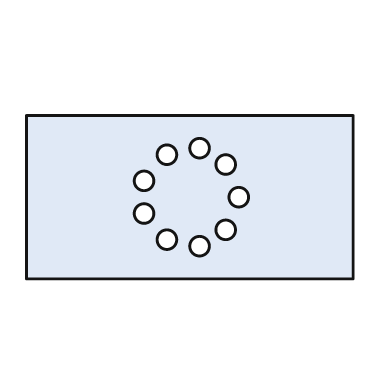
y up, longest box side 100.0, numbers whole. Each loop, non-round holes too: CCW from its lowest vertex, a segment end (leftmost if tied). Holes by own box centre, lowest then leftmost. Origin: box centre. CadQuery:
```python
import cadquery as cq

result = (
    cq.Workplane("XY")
    .moveTo(-50.0, -25.0)
    .lineTo(50.0, -25.0)
    .lineTo(50.0, 25.0)
    .lineTo(-50.0, 25.0)
    .close()
    .moveTo(3.0, -15.0)
    .circle(3.0)
    .moveTo(-7.0, -13.0)
    .circle(3.0)
    .moveTo(11.0, -10.0)
    .circle(3.0)
    .moveTo(-14.0, -5.0)
    .circle(3.0)
    .moveTo(15.0, 0.0)
    .circle(3.0)
    .moveTo(-14.0, 5.0)
    .circle(3.0)
    .moveTo(11.0, 10.0)
    .circle(3.0)
    .moveTo(-7.0, 13.0)
    .circle(3.0)
    .moveTo(3.0, 15.0)
    .circle(3.0)
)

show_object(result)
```